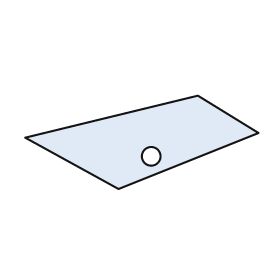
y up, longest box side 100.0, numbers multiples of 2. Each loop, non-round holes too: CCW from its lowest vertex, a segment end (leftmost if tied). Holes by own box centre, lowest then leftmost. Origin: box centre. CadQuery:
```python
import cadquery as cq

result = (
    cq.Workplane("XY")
    .moveTo(-10.0, -20.0)
    .lineTo(50.0, 4.0)
    .lineTo(24.0, 20.0)
    .lineTo(-50.0, 2.0)
    .close()
    .moveTo(4.0, -6.0)
    .circle(4.0)
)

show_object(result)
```